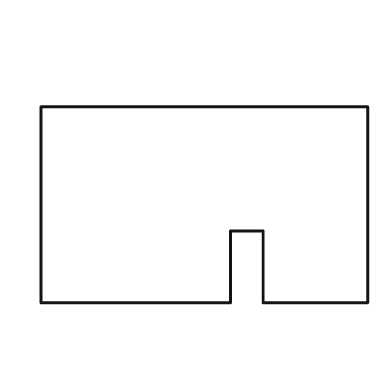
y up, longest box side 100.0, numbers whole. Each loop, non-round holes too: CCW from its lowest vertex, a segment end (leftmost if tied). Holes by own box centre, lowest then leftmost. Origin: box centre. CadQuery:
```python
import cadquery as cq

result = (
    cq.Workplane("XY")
    .moveTo(-50.0, -30.0)
    .lineTo(8.0, -30.0)
    .lineTo(8.0, -8.0)
    .lineTo(18.0, -8.0)
    .lineTo(18.0, -30.0)
    .lineTo(50.0, -30.0)
    .lineTo(50.0, 30.0)
    .lineTo(-50.0, 30.0)
    .close()
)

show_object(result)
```